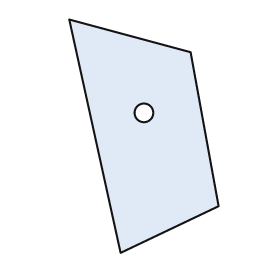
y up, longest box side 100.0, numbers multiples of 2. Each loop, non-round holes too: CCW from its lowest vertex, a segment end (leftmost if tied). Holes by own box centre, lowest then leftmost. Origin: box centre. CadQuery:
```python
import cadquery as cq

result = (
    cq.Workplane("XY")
    .moveTo(-10.0, -50.0)
    .lineTo(32.0, -30.0)
    .lineTo(20.0, 36.0)
    .lineTo(-32.0, 50.0)
    .close()
    .moveTo(0.0, 10.0)
    .circle(4.0)
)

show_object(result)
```